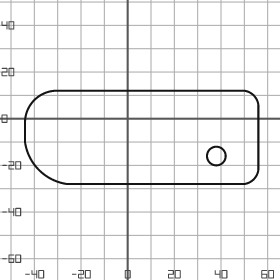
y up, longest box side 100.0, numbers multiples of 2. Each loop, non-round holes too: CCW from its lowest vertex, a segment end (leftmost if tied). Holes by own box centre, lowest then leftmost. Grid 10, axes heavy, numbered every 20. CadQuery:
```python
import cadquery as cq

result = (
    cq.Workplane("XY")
    .moveTo(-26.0, -28.0)
    .lineTo(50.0, -28.0)
    .threePointArc((54.0, -26.0), (56.0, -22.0))
    .lineTo(56.0, 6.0)
    .threePointArc((54.0, 10.0), (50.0, 12.0))
    .lineTo(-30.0, 12.0)
    .threePointArc((-40.0, 8.0), (-44.0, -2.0))
    .lineTo(-44.0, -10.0)
    .threePointArc((-38.0, -22.0), (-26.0, -28.0))
    .close()
    .moveTo(38.0, -16.0)
    .circle(4.0)
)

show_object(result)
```